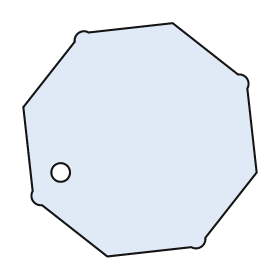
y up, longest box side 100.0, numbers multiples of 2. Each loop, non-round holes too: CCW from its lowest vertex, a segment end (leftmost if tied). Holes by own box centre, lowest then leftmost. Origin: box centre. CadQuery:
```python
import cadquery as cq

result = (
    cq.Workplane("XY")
    .moveTo(-14.0, -50.0)
    .lineTo(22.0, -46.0)
    .threePointArc((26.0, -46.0), (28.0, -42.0))
    .lineTo(50.0, -14.0)
    .lineTo(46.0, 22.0)
    .threePointArc((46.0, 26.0), (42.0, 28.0))
    .lineTo(14.0, 50.0)
    .lineTo(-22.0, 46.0)
    .threePointArc((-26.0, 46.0), (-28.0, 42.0))
    .lineTo(-50.0, 14.0)
    .lineTo(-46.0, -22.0)
    .threePointArc((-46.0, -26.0), (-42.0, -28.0))
    .close()
    .moveTo(-34.0, -14.0)
    .circle(4.0)
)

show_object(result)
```